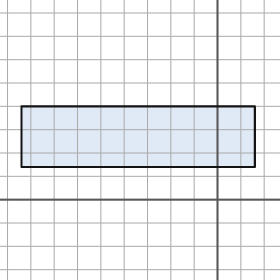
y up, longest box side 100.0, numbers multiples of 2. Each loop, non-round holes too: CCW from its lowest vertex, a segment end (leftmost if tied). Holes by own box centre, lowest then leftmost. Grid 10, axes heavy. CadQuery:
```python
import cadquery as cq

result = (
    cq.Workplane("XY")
    .moveTo(-84.0, 14.0)
    .lineTo(16.0, 14.0)
    .lineTo(16.0, 40.0)
    .lineTo(-84.0, 40.0)
    .close()
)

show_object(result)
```